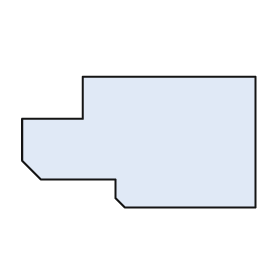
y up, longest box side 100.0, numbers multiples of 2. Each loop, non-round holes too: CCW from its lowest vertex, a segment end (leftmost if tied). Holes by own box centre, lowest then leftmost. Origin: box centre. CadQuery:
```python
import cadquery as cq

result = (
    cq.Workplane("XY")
    .moveTo(-6.0, -28.0)
    .lineTo(50.0, -28.0)
    .lineTo(50.0, 28.0)
    .lineTo(-24.0, 28.0)
    .lineTo(-24.0, 10.0)
    .lineTo(-50.0, 10.0)
    .lineTo(-50.0, -8.0)
    .lineTo(-42.0, -16.0)
    .lineTo(-10.0, -16.0)
    .lineTo(-10.0, -24.0)
    .close()
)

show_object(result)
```